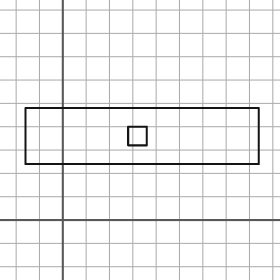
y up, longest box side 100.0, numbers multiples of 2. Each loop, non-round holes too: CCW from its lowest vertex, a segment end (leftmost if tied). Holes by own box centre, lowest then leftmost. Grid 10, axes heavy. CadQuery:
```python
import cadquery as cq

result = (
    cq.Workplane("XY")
    .moveTo(-16.0, 24.0)
    .lineTo(84.0, 24.0)
    .lineTo(84.0, 48.0)
    .lineTo(-16.0, 48.0)
    .close()
    .moveTo(28.0, 32.0)
    .lineTo(36.0, 32.0)
    .lineTo(36.0, 40.0)
    .lineTo(28.0, 40.0)
    .close()
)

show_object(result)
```